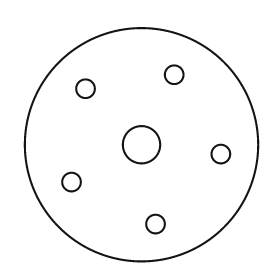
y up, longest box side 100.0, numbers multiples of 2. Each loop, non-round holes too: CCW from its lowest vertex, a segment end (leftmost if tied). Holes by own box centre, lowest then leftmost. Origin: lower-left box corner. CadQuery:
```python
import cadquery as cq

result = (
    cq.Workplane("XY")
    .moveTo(50.0, 50.0)
    .circle(50.0)
    .moveTo(56.0, 16.0)
    .circle(4.0)
    .moveTo(20.0, 34.0)
    .circle(4.0)
    .moveTo(84.0, 46.0)
    .circle(4.0)
    .moveTo(50.0, 50.0)
    .circle(8.0)
    .moveTo(26.0, 74.0)
    .circle(4.0)
    .moveTo(64.0, 80.0)
    .circle(4.0)
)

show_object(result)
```